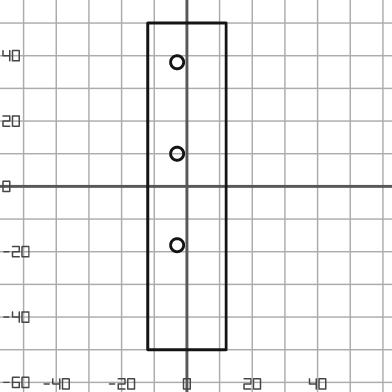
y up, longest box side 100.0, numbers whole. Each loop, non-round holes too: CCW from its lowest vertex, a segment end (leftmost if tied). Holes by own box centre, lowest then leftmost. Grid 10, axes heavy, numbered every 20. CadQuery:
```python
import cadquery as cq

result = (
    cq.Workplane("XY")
    .moveTo(-12.0, -50.0)
    .lineTo(12.0, -50.0)
    .lineTo(12.0, 50.0)
    .lineTo(-12.0, 50.0)
    .close()
    .moveTo(-3.0, -18.0)
    .circle(2.0)
    .moveTo(-3.0, 10.0)
    .circle(2.0)
    .moveTo(-3.0, 38.0)
    .circle(2.0)
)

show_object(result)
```